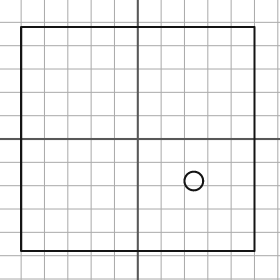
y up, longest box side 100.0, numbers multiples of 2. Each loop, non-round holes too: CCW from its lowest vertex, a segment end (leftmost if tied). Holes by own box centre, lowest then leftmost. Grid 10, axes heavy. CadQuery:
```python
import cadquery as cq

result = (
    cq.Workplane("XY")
    .moveTo(-50.0, -48.0)
    .lineTo(50.0, -48.0)
    .lineTo(50.0, 48.0)
    .lineTo(-50.0, 48.0)
    .close()
    .moveTo(24.0, -18.0)
    .circle(4.0)
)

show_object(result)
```